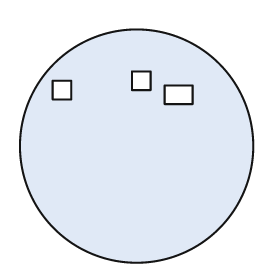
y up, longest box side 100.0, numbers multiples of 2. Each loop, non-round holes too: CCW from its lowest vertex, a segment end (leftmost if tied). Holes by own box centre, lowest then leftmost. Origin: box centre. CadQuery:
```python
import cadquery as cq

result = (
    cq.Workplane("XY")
    .moveTo(0.0, 0.0)
    .circle(50.0)
    .moveTo(12.0, 18.0)
    .lineTo(24.0, 18.0)
    .lineTo(24.0, 26.0)
    .lineTo(12.0, 26.0)
    .close()
    .moveTo(-36.0, 20.0)
    .lineTo(-28.0, 20.0)
    .lineTo(-28.0, 28.0)
    .lineTo(-36.0, 28.0)
    .close()
    .moveTo(-2.0, 24.0)
    .lineTo(6.0, 24.0)
    .lineTo(6.0, 32.0)
    .lineTo(-2.0, 32.0)
    .close()
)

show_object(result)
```